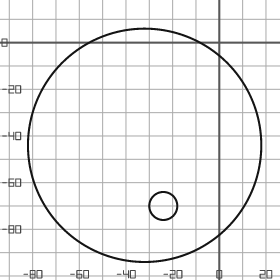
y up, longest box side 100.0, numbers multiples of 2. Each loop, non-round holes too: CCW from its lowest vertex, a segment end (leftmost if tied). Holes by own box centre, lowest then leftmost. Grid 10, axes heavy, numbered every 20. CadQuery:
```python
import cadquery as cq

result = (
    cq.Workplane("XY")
    .moveTo(-32.0, -44.0)
    .circle(50.0)
    .moveTo(-24.0, -70.0)
    .circle(6.0)
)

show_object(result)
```